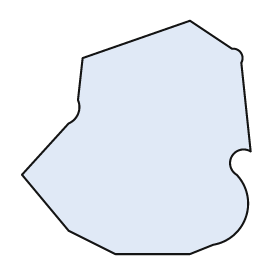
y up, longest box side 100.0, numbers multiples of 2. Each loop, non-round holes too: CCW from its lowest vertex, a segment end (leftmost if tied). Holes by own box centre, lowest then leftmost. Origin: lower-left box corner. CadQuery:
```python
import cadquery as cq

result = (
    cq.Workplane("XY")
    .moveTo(40.0, 0.0)
    .lineTo(72.0, 0.0)
    .lineTo(82.0, 4.0)
    .threePointArc((96.0, 16.0), (92.0, 34.0))
    .threePointArc((90.0, 42.0), (98.0, 44.0))
    .lineTo(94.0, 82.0)
    .threePointArc((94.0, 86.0), (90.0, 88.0))
    .lineTo(72.0, 100.0)
    .lineTo(26.0, 84.0)
    .lineTo(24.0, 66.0)
    .threePointArc((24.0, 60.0), (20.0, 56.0))
    .lineTo(0.0, 34.0)
    .lineTo(20.0, 10.0)
    .close()
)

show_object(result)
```